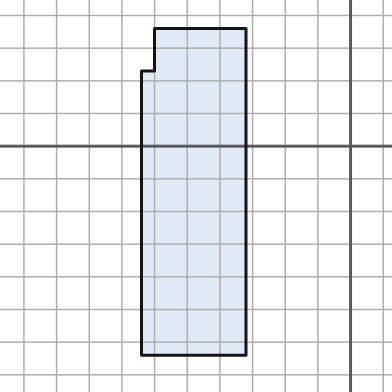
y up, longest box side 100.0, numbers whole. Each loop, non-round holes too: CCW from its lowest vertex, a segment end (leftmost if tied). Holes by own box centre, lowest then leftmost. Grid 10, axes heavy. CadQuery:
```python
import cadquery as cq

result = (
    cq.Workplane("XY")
    .moveTo(-64.0, -64.0)
    .lineTo(-32.0, -64.0)
    .lineTo(-32.0, 36.0)
    .lineTo(-60.0, 36.0)
    .lineTo(-60.0, 23.0)
    .lineTo(-64.0, 23.0)
    .close()
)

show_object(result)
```